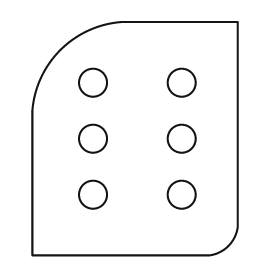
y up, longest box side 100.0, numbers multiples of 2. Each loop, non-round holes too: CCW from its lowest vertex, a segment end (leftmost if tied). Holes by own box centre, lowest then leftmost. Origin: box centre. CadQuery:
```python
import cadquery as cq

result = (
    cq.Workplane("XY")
    .moveTo(-44.0, -50.0)
    .lineTo(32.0, -50.0)
    .threePointArc((40.0, -46.0), (44.0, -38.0))
    .lineTo(44.0, 50.0)
    .lineTo(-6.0, 50.0)
    .threePointArc((-32.0, 38.0), (-44.0, 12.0))
    .close()
    .moveTo(-18.0, -24.0)
    .circle(6.0)
    .moveTo(20.0, -24.0)
    .circle(6.0)
    .moveTo(-18.0, 0.0)
    .circle(6.0)
    .moveTo(20.0, 0.0)
    .circle(6.0)
    .moveTo(-18.0, 24.0)
    .circle(6.0)
    .moveTo(20.0, 24.0)
    .circle(6.0)
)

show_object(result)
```